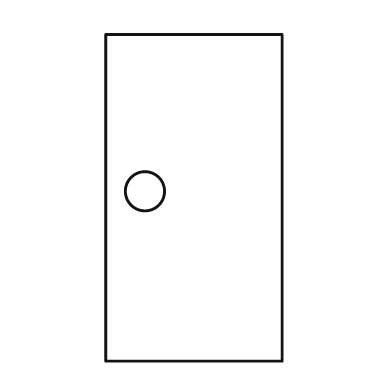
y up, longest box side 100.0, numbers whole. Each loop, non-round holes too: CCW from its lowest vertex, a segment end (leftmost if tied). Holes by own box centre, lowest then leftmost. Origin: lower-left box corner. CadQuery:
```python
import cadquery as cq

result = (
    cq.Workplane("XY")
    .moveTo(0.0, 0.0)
    .lineTo(54.0, 0.0)
    .lineTo(54.0, 100.0)
    .lineTo(0.0, 100.0)
    .close()
    .moveTo(12.0, 52.0)
    .circle(6.0)
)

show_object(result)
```